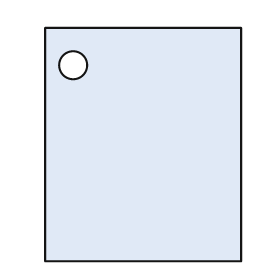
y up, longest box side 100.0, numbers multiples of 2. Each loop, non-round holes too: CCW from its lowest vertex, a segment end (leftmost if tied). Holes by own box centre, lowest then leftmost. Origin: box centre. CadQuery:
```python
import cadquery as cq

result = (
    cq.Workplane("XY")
    .moveTo(-42.0, -50.0)
    .lineTo(42.0, -50.0)
    .lineTo(42.0, 50.0)
    .lineTo(-42.0, 50.0)
    .close()
    .moveTo(-30.0, 34.0)
    .circle(6.0)
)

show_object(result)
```